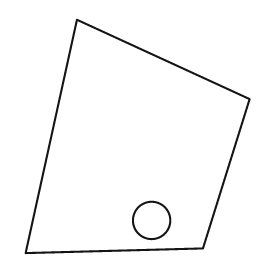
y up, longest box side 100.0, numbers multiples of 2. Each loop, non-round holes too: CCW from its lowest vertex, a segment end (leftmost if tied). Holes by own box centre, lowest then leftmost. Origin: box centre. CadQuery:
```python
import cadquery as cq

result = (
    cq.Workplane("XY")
    .moveTo(-48.0, -50.0)
    .lineTo(28.0, -48.0)
    .lineTo(48.0, 16.0)
    .lineTo(-26.0, 50.0)
    .close()
    .moveTo(6.0, -36.0)
    .circle(8.0)
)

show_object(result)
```